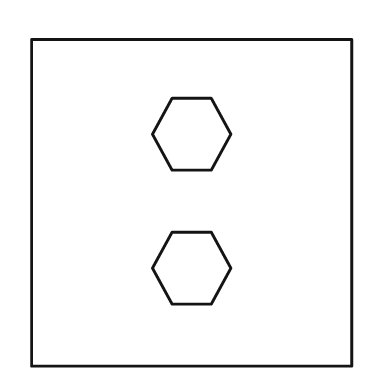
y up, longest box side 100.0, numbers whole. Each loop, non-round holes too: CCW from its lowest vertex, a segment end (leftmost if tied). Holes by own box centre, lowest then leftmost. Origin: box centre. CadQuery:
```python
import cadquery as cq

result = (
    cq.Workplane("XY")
    .moveTo(-49.0, -50.0)
    .lineTo(49.0, -50.0)
    .lineTo(49.0, 50.0)
    .lineTo(-49.0, 50.0)
    .close()
    .moveTo(-6.0, -31.0)
    .lineTo(6.0, -31.0)
    .lineTo(12.0, -20.0)
    .lineTo(6.0, -9.0)
    .lineTo(-6.0, -9.0)
    .lineTo(-12.0, -20.0)
    .close()
    .moveTo(-6.0, 10.0)
    .lineTo(6.0, 10.0)
    .lineTo(12.0, 21.0)
    .lineTo(6.0, 32.0)
    .lineTo(-6.0, 32.0)
    .lineTo(-12.0, 21.0)
    .close()
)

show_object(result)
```